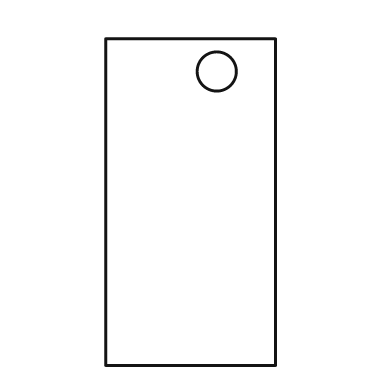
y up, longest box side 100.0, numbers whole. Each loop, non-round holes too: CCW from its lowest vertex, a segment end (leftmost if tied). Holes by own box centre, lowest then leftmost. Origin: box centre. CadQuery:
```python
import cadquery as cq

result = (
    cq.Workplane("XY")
    .moveTo(-26.0, -50.0)
    .lineTo(26.0, -50.0)
    .lineTo(26.0, 50.0)
    .lineTo(-26.0, 50.0)
    .close()
    .moveTo(8.0, 40.0)
    .circle(6.0)
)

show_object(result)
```